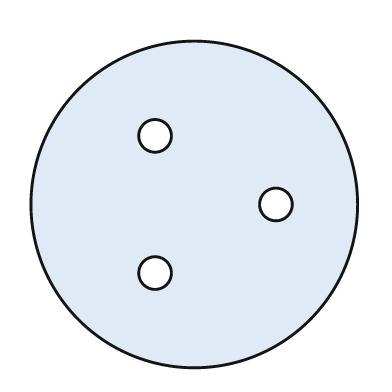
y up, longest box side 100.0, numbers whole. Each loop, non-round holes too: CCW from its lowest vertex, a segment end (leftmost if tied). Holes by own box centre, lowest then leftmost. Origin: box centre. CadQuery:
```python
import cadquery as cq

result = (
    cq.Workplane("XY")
    .moveTo(0.0, 0.0)
    .circle(50.0)
    .moveTo(-12.0, -21.0)
    .circle(5.0)
    .moveTo(25.0, 0.0)
    .circle(5.0)
    .moveTo(-12.0, 21.0)
    .circle(5.0)
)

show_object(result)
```